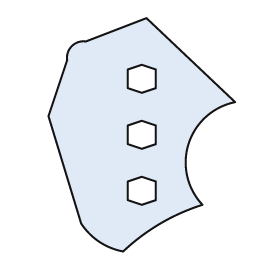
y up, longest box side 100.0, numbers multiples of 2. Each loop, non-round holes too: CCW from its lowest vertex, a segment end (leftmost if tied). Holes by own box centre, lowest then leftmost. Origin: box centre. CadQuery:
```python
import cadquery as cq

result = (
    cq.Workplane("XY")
    .moveTo(-8.0, -50.0)
    .threePointArc((8.0, -38.0), (26.0, -30.0))
    .threePointArc((20.0, -4.0), (40.0, 14.0))
    .lineTo(2.0, 50.0)
    .lineTo(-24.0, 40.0)
    .threePointArc((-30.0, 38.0), (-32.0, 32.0))
    .lineTo(-40.0, 8.0)
    .lineTo(-26.0, -38.0)
    .threePointArc((-18.0, -46.0), (-8.0, -50.0))
    .close()
    .moveTo(0.0, -30.0)
    .lineTo(6.0, -28.0)
    .lineTo(6.0, -20.0)
    .lineTo(0.0, -18.0)
    .lineTo(-6.0, -20.0)
    .lineTo(-6.0, -28.0)
    .close()
    .moveTo(0.0, -6.0)
    .lineTo(6.0, -4.0)
    .lineTo(6.0, 4.0)
    .lineTo(0.0, 6.0)
    .lineTo(-6.0, 4.0)
    .lineTo(-6.0, -4.0)
    .close()
    .moveTo(0.0, 18.0)
    .lineTo(6.0, 20.0)
    .lineTo(6.0, 28.0)
    .lineTo(0.0, 30.0)
    .lineTo(-6.0, 28.0)
    .lineTo(-6.0, 20.0)
    .close()
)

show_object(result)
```